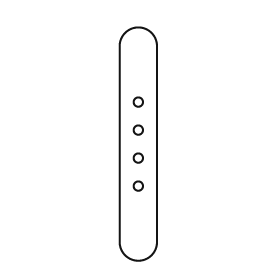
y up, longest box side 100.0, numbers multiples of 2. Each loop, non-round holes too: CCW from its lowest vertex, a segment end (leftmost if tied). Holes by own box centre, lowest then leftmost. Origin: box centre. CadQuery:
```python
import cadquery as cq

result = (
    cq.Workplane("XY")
    .moveTo(-8.0, -42.0)
    .threePointArc((0.0, -50.0), (8.0, -42.0))
    .lineTo(8.0, 42.0)
    .threePointArc((0.0, 50.0), (-8.0, 42.0))
    .close()
    .moveTo(0.0, -18.0)
    .circle(2.0)
    .moveTo(0.0, -6.0)
    .circle(2.0)
    .moveTo(0.0, 6.0)
    .circle(2.0)
    .moveTo(0.0, 18.0)
    .circle(2.0)
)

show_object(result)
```